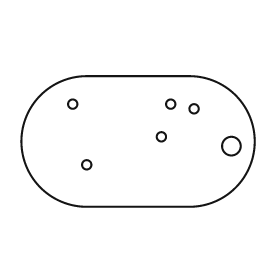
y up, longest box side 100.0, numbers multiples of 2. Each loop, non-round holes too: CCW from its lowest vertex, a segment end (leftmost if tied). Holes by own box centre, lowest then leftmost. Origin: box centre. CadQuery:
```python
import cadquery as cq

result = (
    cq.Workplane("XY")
    .moveTo(-22.0, -28.0)
    .lineTo(22.0, -28.0)
    .threePointArc((50.0, 0.0), (22.0, 28.0))
    .lineTo(-22.0, 28.0)
    .threePointArc((-50.0, 0.0), (-22.0, -28.0))
    .close()
    .moveTo(-22.0, -10.0)
    .circle(2.0)
    .moveTo(40.0, -2.0)
    .circle(4.0)
    .moveTo(10.0, 2.0)
    .circle(2.0)
    .moveTo(24.0, 14.0)
    .circle(2.0)
    .moveTo(-28.0, 16.0)
    .circle(2.0)
    .moveTo(14.0, 16.0)
    .circle(2.0)
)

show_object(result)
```